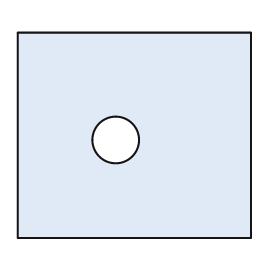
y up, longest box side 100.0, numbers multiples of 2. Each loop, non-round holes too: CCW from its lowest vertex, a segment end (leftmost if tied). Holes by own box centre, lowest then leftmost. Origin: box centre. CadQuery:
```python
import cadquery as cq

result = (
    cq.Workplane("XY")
    .moveTo(-50.0, -44.0)
    .lineTo(50.0, -44.0)
    .lineTo(50.0, 44.0)
    .lineTo(-50.0, 44.0)
    .close()
    .moveTo(-8.0, -2.0)
    .circle(10.0)
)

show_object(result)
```